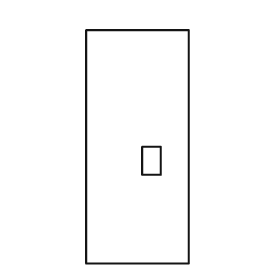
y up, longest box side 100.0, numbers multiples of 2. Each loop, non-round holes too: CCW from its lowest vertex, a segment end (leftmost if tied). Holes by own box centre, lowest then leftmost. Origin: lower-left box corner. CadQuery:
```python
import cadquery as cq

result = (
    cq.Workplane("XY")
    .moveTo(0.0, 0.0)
    .lineTo(44.0, 0.0)
    .lineTo(44.0, 100.0)
    .lineTo(0.0, 100.0)
    .close()
    .moveTo(24.0, 38.0)
    .lineTo(32.0, 38.0)
    .lineTo(32.0, 50.0)
    .lineTo(24.0, 50.0)
    .close()
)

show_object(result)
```